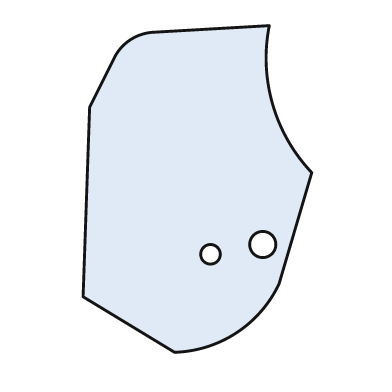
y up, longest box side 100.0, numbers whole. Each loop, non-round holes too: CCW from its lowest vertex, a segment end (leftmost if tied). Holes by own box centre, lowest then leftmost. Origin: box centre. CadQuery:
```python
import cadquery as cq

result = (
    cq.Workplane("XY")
    .moveTo(-7.0, -50.0)
    .threePointArc((12.0, -44.0), (25.0, -29.0))
    .lineTo(35.0, 5.0)
    .threePointArc((23.0, 26.0), (22.0, 50.0))
    .lineTo(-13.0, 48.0)
    .threePointArc((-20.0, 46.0), (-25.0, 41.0))
    .lineTo(-33.0, 25.0)
    .lineTo(-35.0, -33.0)
    .close()
    .moveTo(4.0, -20.0)
    .circle(3.0)
    .moveTo(20.0, -17.0)
    .circle(4.0)
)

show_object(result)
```